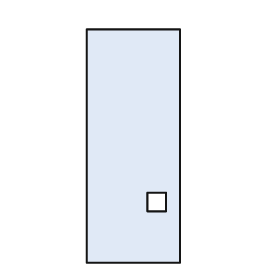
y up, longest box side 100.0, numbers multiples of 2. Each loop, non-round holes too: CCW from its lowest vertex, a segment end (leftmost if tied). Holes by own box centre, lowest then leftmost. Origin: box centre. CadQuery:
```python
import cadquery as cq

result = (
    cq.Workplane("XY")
    .moveTo(-20.0, -50.0)
    .lineTo(20.0, -50.0)
    .lineTo(20.0, 50.0)
    .lineTo(-20.0, 50.0)
    .close()
    .moveTo(6.0, -28.0)
    .lineTo(14.0, -28.0)
    .lineTo(14.0, -20.0)
    .lineTo(6.0, -20.0)
    .close()
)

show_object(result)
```